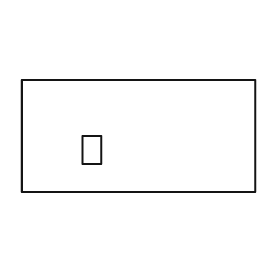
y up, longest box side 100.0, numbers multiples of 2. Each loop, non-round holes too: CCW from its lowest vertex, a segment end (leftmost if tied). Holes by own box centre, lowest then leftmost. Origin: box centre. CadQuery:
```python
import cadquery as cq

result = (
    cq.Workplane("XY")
    .moveTo(-50.0, -24.0)
    .lineTo(50.0, -24.0)
    .lineTo(50.0, 24.0)
    .lineTo(-50.0, 24.0)
    .close()
    .moveTo(-24.0, -12.0)
    .lineTo(-16.0, -12.0)
    .lineTo(-16.0, 0.0)
    .lineTo(-24.0, 0.0)
    .close()
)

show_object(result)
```